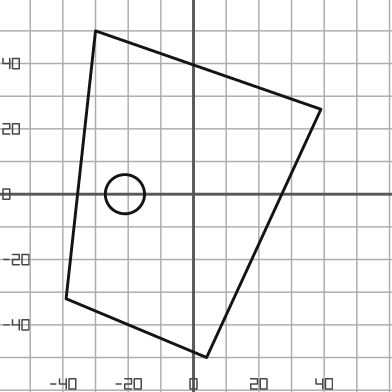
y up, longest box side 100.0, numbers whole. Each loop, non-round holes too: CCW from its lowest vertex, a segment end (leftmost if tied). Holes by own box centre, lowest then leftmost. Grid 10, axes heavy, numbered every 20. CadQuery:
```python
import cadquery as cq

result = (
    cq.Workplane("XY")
    .moveTo(4.0, -50.0)
    .lineTo(39.0, 26.0)
    .lineTo(-30.0, 50.0)
    .lineTo(-39.0, -32.0)
    .close()
    .moveTo(-21.0, 0.0)
    .circle(6.0)
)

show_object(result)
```